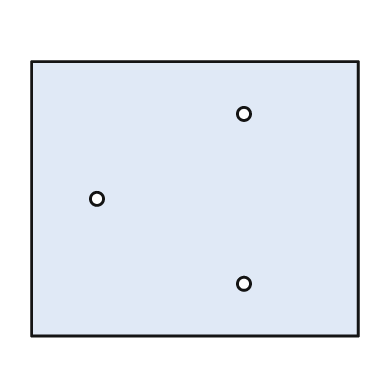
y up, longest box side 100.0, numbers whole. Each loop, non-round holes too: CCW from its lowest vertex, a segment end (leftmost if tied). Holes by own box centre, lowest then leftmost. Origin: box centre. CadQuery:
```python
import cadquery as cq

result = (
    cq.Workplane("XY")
    .moveTo(-50.0, -42.0)
    .lineTo(50.0, -42.0)
    .lineTo(50.0, 42.0)
    .lineTo(-50.0, 42.0)
    .close()
    .moveTo(15.0, -26.0)
    .circle(2.0)
    .moveTo(-30.0, 0.0)
    .circle(2.0)
    .moveTo(15.0, 26.0)
    .circle(2.0)
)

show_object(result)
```